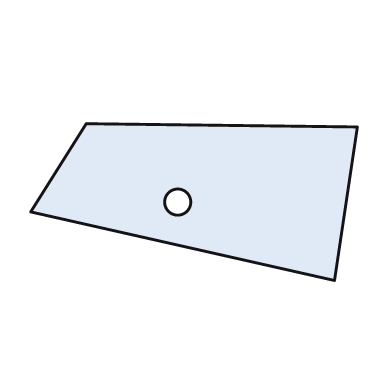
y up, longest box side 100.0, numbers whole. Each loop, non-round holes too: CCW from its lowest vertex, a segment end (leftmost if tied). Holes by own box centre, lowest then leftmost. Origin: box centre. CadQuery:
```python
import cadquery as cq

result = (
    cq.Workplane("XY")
    .moveTo(43.0, -24.0)
    .lineTo(50.0, 23.0)
    .lineTo(-33.0, 24.0)
    .lineTo(-50.0, -3.0)
    .close()
    .moveTo(-5.0, 0.0)
    .circle(4.0)
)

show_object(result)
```